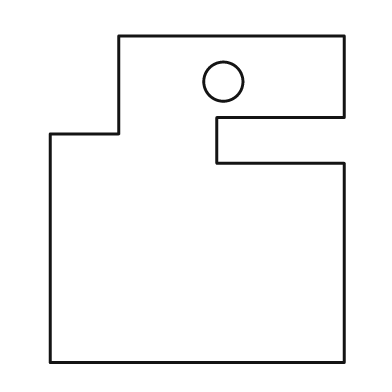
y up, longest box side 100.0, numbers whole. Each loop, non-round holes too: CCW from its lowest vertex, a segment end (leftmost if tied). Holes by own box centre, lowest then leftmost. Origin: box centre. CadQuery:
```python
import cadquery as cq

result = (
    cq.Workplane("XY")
    .moveTo(-45.0, -50.0)
    .lineTo(45.0, -50.0)
    .lineTo(45.0, 11.0)
    .lineTo(6.0, 11.0)
    .lineTo(6.0, 25.0)
    .lineTo(45.0, 25.0)
    .lineTo(45.0, 50.0)
    .lineTo(-24.0, 50.0)
    .lineTo(-24.0, 20.0)
    .lineTo(-45.0, 20.0)
    .close()
    .moveTo(8.0, 36.0)
    .circle(6.0)
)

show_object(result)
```